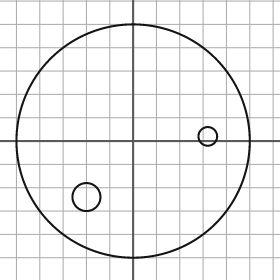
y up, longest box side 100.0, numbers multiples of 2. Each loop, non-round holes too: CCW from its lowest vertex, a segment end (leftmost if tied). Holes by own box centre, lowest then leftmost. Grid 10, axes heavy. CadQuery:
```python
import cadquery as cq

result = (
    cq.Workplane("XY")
    .moveTo(0.0, 0.0)
    .circle(50.0)
    .moveTo(-20.0, -24.0)
    .circle(6.0)
    .moveTo(32.0, 2.0)
    .circle(4.0)
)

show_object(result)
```